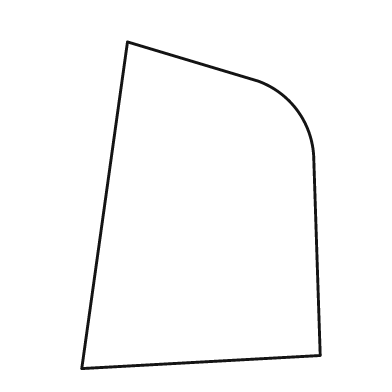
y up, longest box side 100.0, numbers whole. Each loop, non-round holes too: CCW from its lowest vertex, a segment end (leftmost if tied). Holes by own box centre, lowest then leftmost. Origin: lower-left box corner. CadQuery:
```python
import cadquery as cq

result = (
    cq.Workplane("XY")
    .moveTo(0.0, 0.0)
    .lineTo(73.0, 4.0)
    .lineTo(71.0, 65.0)
    .threePointArc((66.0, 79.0), (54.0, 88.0))
    .lineTo(14.0, 100.0)
    .close()
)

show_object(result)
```